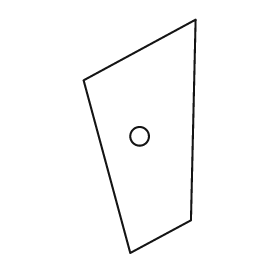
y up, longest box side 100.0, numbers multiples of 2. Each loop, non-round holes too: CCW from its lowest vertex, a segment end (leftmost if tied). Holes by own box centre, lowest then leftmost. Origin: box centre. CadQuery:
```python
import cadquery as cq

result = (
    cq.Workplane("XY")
    .moveTo(-4.0, -50.0)
    .lineTo(22.0, -36.0)
    .lineTo(24.0, 50.0)
    .lineTo(-24.0, 24.0)
    .close()
    .moveTo(0.0, 0.0)
    .circle(4.0)
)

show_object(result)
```